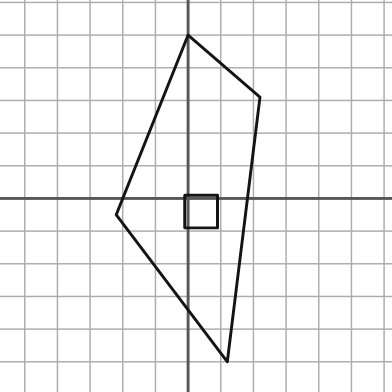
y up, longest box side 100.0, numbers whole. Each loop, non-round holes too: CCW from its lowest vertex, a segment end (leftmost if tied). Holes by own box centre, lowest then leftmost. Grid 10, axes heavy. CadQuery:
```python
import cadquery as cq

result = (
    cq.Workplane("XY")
    .moveTo(12.0, -50.0)
    .lineTo(22.0, 31.0)
    .lineTo(0.0, 50.0)
    .lineTo(-22.0, -5.0)
    .close()
    .moveTo(-1.0, -9.0)
    .lineTo(9.0, -9.0)
    .lineTo(9.0, 1.0)
    .lineTo(-1.0, 1.0)
    .close()
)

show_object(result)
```